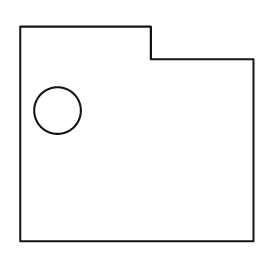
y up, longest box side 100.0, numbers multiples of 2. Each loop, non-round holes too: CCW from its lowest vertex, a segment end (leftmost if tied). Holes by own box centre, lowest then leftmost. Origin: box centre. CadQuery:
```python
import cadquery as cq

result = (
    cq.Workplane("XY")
    .moveTo(-50.0, -46.0)
    .lineTo(50.0, -46.0)
    .lineTo(50.0, 32.0)
    .lineTo(6.0, 32.0)
    .lineTo(6.0, 46.0)
    .lineTo(-50.0, 46.0)
    .close()
    .moveTo(-34.0, 10.0)
    .circle(10.0)
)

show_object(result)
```